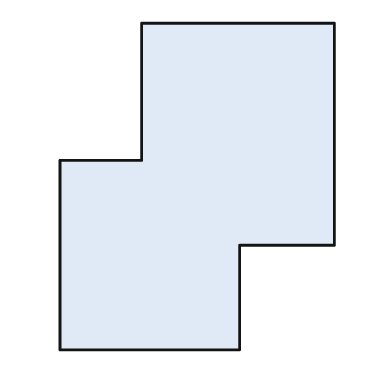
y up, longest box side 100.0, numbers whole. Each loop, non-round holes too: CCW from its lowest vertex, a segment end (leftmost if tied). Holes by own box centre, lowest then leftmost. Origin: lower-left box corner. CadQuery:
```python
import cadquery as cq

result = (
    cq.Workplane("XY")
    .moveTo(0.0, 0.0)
    .lineTo(55.0, 0.0)
    .lineTo(55.0, 32.0)
    .lineTo(84.0, 32.0)
    .lineTo(84.0, 100.0)
    .lineTo(25.0, 100.0)
    .lineTo(25.0, 58.0)
    .lineTo(0.0, 58.0)
    .close()
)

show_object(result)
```